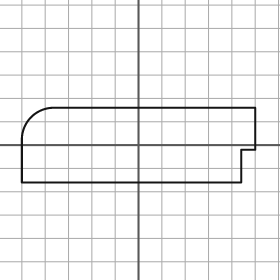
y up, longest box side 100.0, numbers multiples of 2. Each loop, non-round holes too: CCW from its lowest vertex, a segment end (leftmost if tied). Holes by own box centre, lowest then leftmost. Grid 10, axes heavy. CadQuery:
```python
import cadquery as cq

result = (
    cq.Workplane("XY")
    .moveTo(-50.0, -16.0)
    .lineTo(44.0, -16.0)
    .lineTo(44.0, -2.0)
    .lineTo(50.0, -2.0)
    .lineTo(50.0, 16.0)
    .lineTo(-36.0, 16.0)
    .threePointArc((-46.0, 12.0), (-50.0, 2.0))
    .close()
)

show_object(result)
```